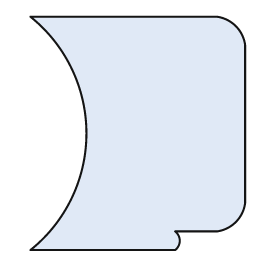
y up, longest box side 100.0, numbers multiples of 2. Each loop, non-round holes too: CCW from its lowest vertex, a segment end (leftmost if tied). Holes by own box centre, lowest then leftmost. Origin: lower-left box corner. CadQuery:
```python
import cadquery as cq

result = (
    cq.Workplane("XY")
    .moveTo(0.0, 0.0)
    .lineTo(62.0, 0.0)
    .threePointArc((64.0, 4.0), (62.0, 8.0))
    .lineTo(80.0, 8.0)
    .threePointArc((88.0, 12.0), (92.0, 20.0))
    .lineTo(92.0, 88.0)
    .threePointArc((88.0, 96.0), (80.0, 100.0))
    .lineTo(0.0, 100.0)
    .threePointArc((24.0, 50.0), (0.0, 0.0))
    .close()
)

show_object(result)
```